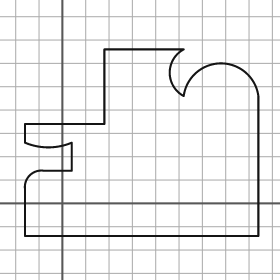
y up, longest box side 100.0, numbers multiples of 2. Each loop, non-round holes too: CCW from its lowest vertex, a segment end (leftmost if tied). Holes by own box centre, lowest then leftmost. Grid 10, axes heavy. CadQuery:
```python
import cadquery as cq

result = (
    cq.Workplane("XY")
    .moveTo(-16.0, -14.0)
    .lineTo(84.0, -14.0)
    .lineTo(84.0, 46.0)
    .threePointArc((68.0, 60.0), (52.0, 46.0))
    .threePointArc((46.0, 56.0), (52.0, 66.0))
    .lineTo(18.0, 66.0)
    .lineTo(18.0, 34.0)
    .lineTo(-16.0, 34.0)
    .lineTo(-16.0, 26.0)
    .threePointArc((-6.0, 24.0), (4.0, 26.0))
    .lineTo(4.0, 14.0)
    .lineTo(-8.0, 14.0)
    .threePointArc((-14.0, 12.0), (-16.0, 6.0))
    .close()
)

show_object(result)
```